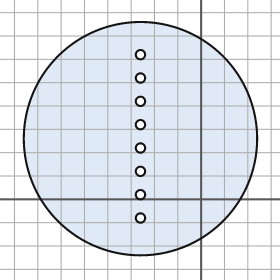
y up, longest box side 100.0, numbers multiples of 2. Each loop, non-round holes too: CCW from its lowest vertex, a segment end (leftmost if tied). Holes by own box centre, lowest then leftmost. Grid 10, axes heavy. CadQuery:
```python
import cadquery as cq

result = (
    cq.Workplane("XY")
    .moveTo(-26.0, 26.0)
    .circle(50.0)
    .moveTo(-26.0, -8.0)
    .circle(2.0)
    .moveTo(-26.0, 2.0)
    .circle(2.0)
    .moveTo(-26.0, 12.0)
    .circle(2.0)
    .moveTo(-26.0, 22.0)
    .circle(2.0)
    .moveTo(-26.0, 32.0)
    .circle(2.0)
    .moveTo(-26.0, 42.0)
    .circle(2.0)
    .moveTo(-26.0, 52.0)
    .circle(2.0)
    .moveTo(-26.0, 62.0)
    .circle(2.0)
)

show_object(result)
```